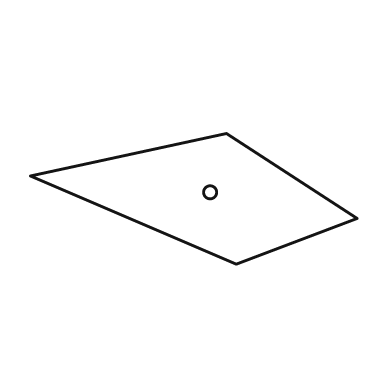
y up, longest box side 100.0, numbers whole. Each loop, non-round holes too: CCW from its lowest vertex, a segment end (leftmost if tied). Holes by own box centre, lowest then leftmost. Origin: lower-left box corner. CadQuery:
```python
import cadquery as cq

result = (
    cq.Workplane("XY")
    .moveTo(63.0, 0.0)
    .lineTo(100.0, 14.0)
    .lineTo(60.0, 40.0)
    .lineTo(0.0, 27.0)
    .close()
    .moveTo(55.0, 22.0)
    .circle(2.0)
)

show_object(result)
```